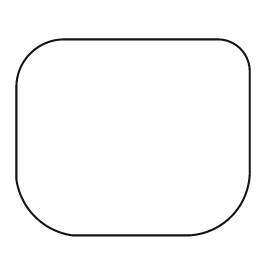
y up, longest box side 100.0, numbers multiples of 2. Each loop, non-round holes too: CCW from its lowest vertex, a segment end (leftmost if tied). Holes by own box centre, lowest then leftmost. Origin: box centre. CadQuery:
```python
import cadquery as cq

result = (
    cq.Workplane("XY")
    .moveTo(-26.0, -42.0)
    .lineTo(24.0, -42.0)
    .threePointArc((42.0, -34.0), (50.0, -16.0))
    .lineTo(50.0, 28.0)
    .threePointArc((46.0, 38.0), (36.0, 42.0))
    .lineTo(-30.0, 42.0)
    .threePointArc((-44.0, 36.0), (-50.0, 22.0))
    .lineTo(-50.0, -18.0)
    .threePointArc((-42.0, -34.0), (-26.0, -42.0))
    .close()
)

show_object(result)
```